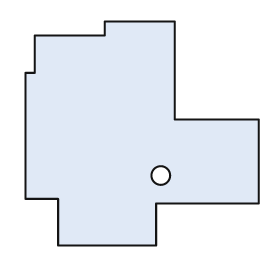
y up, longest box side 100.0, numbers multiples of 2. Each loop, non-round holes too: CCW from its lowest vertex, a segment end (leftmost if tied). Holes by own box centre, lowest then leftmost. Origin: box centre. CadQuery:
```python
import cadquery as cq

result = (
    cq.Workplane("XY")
    .moveTo(-36.0, -48.0)
    .lineTo(6.0, -48.0)
    .lineTo(6.0, -30.0)
    .lineTo(50.0, -30.0)
    .lineTo(50.0, 6.0)
    .lineTo(14.0, 6.0)
    .lineTo(14.0, 48.0)
    .lineTo(-16.0, 48.0)
    .lineTo(-16.0, 42.0)
    .lineTo(-46.0, 42.0)
    .lineTo(-46.0, 26.0)
    .lineTo(-50.0, 26.0)
    .lineTo(-50.0, -28.0)
    .lineTo(-36.0, -28.0)
    .close()
    .moveTo(8.0, -18.0)
    .circle(4.0)
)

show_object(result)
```